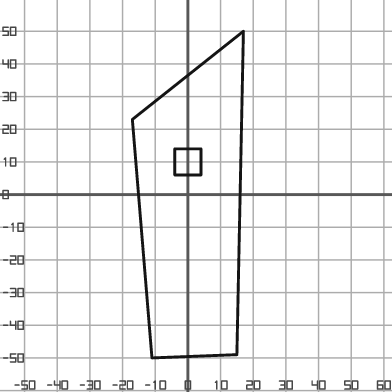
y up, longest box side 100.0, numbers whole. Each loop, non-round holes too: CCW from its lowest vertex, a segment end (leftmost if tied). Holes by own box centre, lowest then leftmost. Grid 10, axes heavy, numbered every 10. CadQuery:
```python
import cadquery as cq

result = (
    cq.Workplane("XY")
    .moveTo(-11.0, -50.0)
    .lineTo(15.0, -49.0)
    .lineTo(17.0, 50.0)
    .lineTo(-17.0, 23.0)
    .close()
    .moveTo(-4.0, 6.0)
    .lineTo(4.0, 6.0)
    .lineTo(4.0, 14.0)
    .lineTo(-4.0, 14.0)
    .close()
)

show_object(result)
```